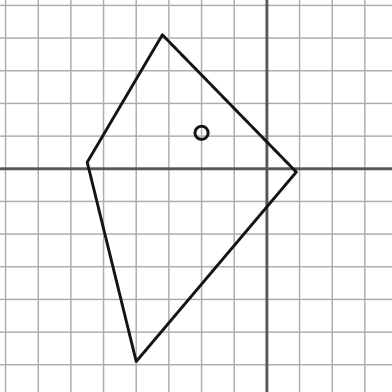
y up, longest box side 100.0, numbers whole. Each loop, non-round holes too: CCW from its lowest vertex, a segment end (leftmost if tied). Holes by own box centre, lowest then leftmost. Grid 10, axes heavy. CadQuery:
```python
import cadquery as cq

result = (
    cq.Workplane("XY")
    .moveTo(-40.0, -59.0)
    .lineTo(9.0, -1.0)
    .lineTo(-32.0, 41.0)
    .lineTo(-55.0, 2.0)
    .close()
    .moveTo(-20.0, 11.0)
    .circle(2.0)
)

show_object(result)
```